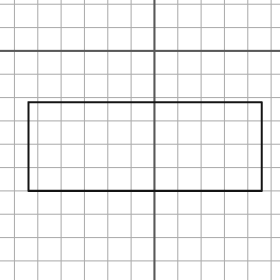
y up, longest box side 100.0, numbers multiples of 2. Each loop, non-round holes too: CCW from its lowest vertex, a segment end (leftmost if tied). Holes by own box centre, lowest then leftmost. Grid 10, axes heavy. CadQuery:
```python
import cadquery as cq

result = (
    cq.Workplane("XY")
    .moveTo(-54.0, -60.0)
    .lineTo(46.0, -60.0)
    .lineTo(46.0, -22.0)
    .lineTo(-54.0, -22.0)
    .close()
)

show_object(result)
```